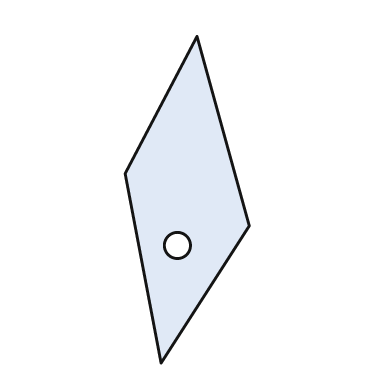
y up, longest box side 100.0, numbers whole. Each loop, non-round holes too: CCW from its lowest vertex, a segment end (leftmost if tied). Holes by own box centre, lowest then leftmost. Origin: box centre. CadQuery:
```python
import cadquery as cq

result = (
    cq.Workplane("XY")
    .moveTo(-8.0, -50.0)
    .lineTo(19.0, -8.0)
    .lineTo(3.0, 50.0)
    .lineTo(-19.0, 8.0)
    .close()
    .moveTo(-3.0, -14.0)
    .circle(4.0)
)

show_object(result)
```